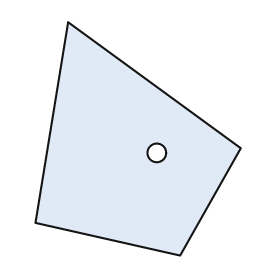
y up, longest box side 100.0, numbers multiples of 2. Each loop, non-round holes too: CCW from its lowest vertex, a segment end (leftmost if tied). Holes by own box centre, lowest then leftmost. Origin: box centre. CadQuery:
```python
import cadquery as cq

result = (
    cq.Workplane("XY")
    .moveTo(18.0, -50.0)
    .lineTo(44.0, -4.0)
    .lineTo(-30.0, 50.0)
    .lineTo(-44.0, -36.0)
    .close()
    .moveTo(8.0, -6.0)
    .circle(4.0)
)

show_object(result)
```